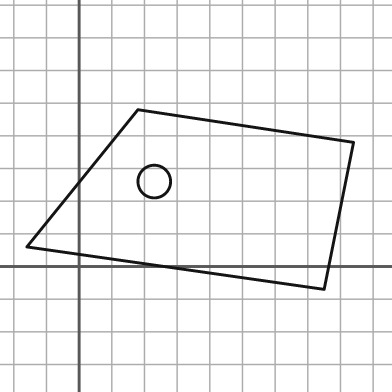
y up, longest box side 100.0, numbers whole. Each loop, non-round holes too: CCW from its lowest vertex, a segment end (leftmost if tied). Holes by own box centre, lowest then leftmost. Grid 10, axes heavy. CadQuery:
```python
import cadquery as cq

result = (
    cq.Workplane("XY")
    .moveTo(75.0, -7.0)
    .lineTo(84.0, 38.0)
    .lineTo(18.0, 48.0)
    .lineTo(-16.0, 6.0)
    .close()
    .moveTo(23.0, 26.0)
    .circle(5.0)
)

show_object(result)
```